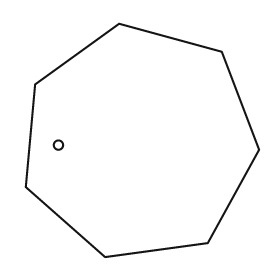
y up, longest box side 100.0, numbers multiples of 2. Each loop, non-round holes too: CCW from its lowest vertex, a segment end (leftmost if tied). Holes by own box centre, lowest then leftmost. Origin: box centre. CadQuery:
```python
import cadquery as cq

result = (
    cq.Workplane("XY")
    .moveTo(-16.0, -50.0)
    .lineTo(28.0, -44.0)
    .lineTo(50.0, -4.0)
    .lineTo(34.0, 38.0)
    .lineTo(-10.0, 50.0)
    .lineTo(-46.0, 24.0)
    .lineTo(-50.0, -20.0)
    .close()
    .moveTo(-36.0, -2.0)
    .circle(2.0)
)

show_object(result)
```